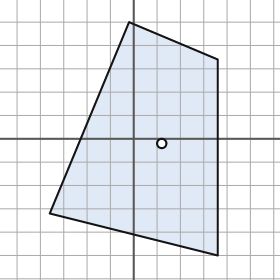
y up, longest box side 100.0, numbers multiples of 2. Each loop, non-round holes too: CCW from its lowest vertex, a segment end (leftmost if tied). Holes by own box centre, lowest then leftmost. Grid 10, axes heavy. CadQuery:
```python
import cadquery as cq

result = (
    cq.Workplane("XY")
    .moveTo(36.0, -50.0)
    .lineTo(36.0, 34.0)
    .lineTo(-2.0, 50.0)
    .lineTo(-36.0, -32.0)
    .close()
    .moveTo(12.0, -2.0)
    .circle(2.0)
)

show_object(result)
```